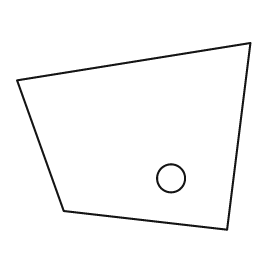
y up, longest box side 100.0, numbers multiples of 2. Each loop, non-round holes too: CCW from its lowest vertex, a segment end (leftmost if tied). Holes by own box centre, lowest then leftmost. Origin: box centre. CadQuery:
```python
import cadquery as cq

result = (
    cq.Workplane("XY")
    .moveTo(40.0, -40.0)
    .lineTo(50.0, 40.0)
    .lineTo(-50.0, 24.0)
    .lineTo(-30.0, -32.0)
    .close()
    .moveTo(16.0, -18.0)
    .circle(6.0)
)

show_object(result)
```